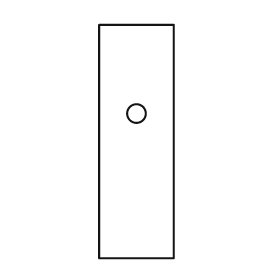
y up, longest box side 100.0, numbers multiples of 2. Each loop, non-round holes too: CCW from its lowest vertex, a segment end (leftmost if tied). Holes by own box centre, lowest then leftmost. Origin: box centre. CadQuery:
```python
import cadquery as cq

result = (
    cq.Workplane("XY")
    .moveTo(-16.0, -50.0)
    .lineTo(16.0, -50.0)
    .lineTo(16.0, 50.0)
    .lineTo(-16.0, 50.0)
    .close()
    .moveTo(0.0, 12.0)
    .circle(4.0)
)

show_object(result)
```